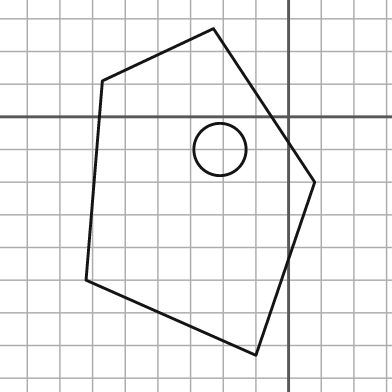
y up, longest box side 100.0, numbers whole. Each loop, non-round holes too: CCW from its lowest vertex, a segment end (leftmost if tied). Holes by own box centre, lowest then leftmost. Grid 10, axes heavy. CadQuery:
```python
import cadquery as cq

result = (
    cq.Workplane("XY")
    .moveTo(-10.0, -73.0)
    .lineTo(8.0, -20.0)
    .lineTo(-23.0, 27.0)
    .lineTo(-57.0, 11.0)
    .lineTo(-62.0, -50.0)
    .close()
    .moveTo(-21.0, -10.0)
    .circle(8.0)
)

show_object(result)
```